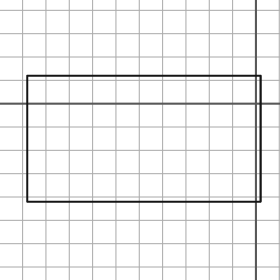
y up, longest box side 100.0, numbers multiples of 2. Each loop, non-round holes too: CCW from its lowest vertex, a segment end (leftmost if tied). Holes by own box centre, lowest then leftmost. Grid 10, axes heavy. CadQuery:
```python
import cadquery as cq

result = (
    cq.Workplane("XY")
    .moveTo(-98.0, -42.0)
    .lineTo(2.0, -42.0)
    .lineTo(2.0, 12.0)
    .lineTo(-98.0, 12.0)
    .close()
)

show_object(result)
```